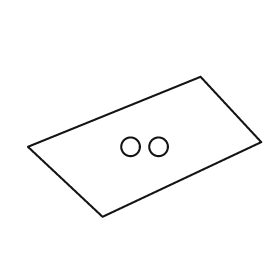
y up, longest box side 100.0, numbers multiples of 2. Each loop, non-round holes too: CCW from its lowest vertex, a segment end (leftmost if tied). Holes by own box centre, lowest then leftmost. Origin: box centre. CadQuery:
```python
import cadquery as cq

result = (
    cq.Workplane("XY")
    .moveTo(-18.0, -30.0)
    .lineTo(50.0, 2.0)
    .lineTo(24.0, 30.0)
    .lineTo(-50.0, 0.0)
    .close()
    .moveTo(-6.0, 0.0)
    .circle(4.0)
    .moveTo(6.0, 0.0)
    .circle(4.0)
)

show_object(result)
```